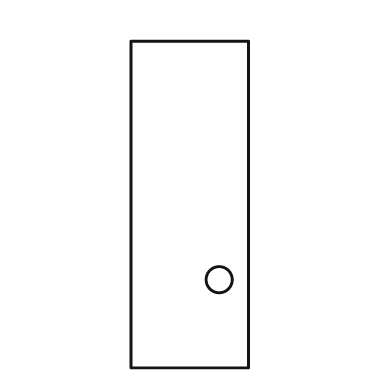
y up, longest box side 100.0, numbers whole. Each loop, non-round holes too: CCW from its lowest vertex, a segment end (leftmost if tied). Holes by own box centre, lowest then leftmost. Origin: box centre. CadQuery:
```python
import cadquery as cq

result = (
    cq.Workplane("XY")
    .moveTo(-18.0, -50.0)
    .lineTo(18.0, -50.0)
    .lineTo(18.0, 50.0)
    .lineTo(-18.0, 50.0)
    .close()
    .moveTo(9.0, -23.0)
    .circle(4.0)
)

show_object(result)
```